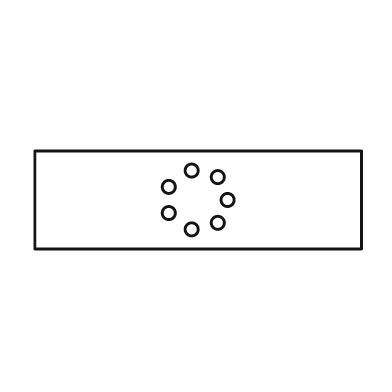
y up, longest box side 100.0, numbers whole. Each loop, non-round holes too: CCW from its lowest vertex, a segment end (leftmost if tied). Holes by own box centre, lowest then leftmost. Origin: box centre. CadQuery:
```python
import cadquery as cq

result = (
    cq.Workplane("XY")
    .moveTo(-50.0, -15.0)
    .lineTo(50.0, -15.0)
    .lineTo(50.0, 15.0)
    .lineTo(-50.0, 15.0)
    .close()
    .moveTo(-2.0, -9.0)
    .circle(2.0)
    .moveTo(6.0, -7.0)
    .circle(2.0)
    .moveTo(-9.0, -4.0)
    .circle(2.0)
    .moveTo(9.0, 0.0)
    .circle(2.0)
    .moveTo(-9.0, 4.0)
    .circle(2.0)
    .moveTo(6.0, 7.0)
    .circle(2.0)
    .moveTo(-2.0, 9.0)
    .circle(2.0)
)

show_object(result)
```